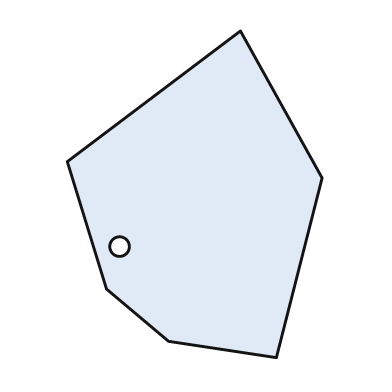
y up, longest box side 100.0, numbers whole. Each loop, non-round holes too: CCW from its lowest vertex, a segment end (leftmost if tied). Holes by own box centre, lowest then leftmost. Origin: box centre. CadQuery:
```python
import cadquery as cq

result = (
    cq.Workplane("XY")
    .moveTo(25.0, -50.0)
    .lineTo(39.0, 5.0)
    .lineTo(14.0, 50.0)
    .lineTo(-39.0, 10.0)
    .lineTo(-27.0, -29.0)
    .lineTo(-8.0, -45.0)
    .close()
    .moveTo(-23.0, -16.0)
    .circle(3.0)
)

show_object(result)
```